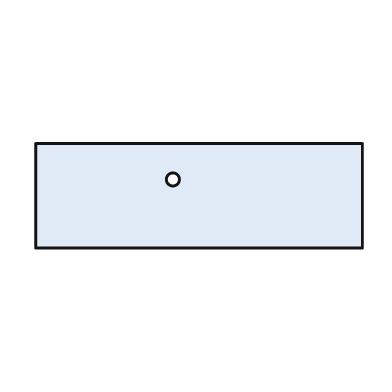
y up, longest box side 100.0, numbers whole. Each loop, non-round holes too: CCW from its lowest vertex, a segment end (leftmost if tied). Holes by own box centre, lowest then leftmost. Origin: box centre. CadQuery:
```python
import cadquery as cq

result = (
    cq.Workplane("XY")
    .moveTo(-50.0, -16.0)
    .lineTo(50.0, -16.0)
    .lineTo(50.0, 16.0)
    .lineTo(-50.0, 16.0)
    .close()
    .moveTo(-8.0, 5.0)
    .circle(2.0)
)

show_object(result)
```